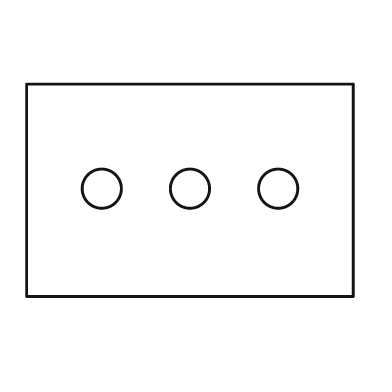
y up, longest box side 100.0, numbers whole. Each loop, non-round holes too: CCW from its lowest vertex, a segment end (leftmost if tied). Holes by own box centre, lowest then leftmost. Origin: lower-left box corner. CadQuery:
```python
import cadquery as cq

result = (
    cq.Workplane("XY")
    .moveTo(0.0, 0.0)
    .lineTo(100.0, 0.0)
    .lineTo(100.0, 65.0)
    .lineTo(0.0, 65.0)
    .close()
    .moveTo(23.0, 33.0)
    .circle(6.0)
    .moveTo(50.0, 33.0)
    .circle(6.0)
    .moveTo(77.0, 33.0)
    .circle(6.0)
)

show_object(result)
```